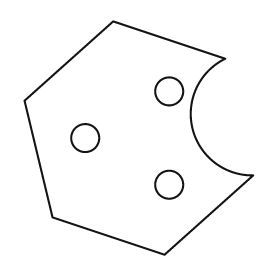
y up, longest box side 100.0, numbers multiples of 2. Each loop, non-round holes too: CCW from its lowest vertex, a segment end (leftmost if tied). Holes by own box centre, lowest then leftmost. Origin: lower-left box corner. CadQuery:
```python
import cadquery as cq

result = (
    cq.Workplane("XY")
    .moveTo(60.0, 0.0)
    .lineTo(98.0, 34.0)
    .threePointArc((72.0, 54.0), (86.0, 84.0))
    .lineTo(38.0, 100.0)
    .lineTo(0.0, 66.0)
    .lineTo(12.0, 16.0)
    .close()
    .moveTo(62.0, 30.0)
    .circle(6.0)
    .moveTo(26.0, 50.0)
    .circle(6.0)
    .moveTo(62.0, 70.0)
    .circle(6.0)
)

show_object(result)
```